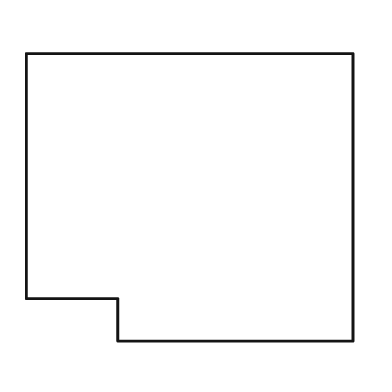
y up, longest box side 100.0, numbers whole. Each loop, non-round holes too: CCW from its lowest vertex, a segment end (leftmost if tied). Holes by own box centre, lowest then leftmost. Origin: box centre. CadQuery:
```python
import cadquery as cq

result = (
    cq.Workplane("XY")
    .moveTo(-22.0, -44.0)
    .lineTo(50.0, -44.0)
    .lineTo(50.0, 44.0)
    .lineTo(-50.0, 44.0)
    .lineTo(-50.0, -31.0)
    .lineTo(-22.0, -31.0)
    .close()
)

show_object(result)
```